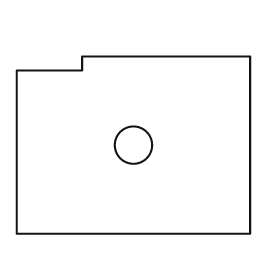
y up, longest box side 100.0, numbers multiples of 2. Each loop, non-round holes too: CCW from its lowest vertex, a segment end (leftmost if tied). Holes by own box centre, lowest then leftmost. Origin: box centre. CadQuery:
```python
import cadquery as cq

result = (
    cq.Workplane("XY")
    .moveTo(-50.0, -38.0)
    .lineTo(50.0, -38.0)
    .lineTo(50.0, 38.0)
    .lineTo(-22.0, 38.0)
    .lineTo(-22.0, 32.0)
    .lineTo(-50.0, 32.0)
    .close()
    .moveTo(0.0, 0.0)
    .circle(8.0)
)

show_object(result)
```